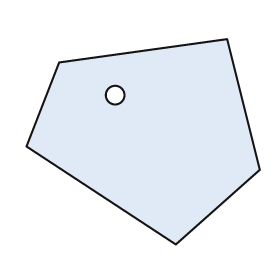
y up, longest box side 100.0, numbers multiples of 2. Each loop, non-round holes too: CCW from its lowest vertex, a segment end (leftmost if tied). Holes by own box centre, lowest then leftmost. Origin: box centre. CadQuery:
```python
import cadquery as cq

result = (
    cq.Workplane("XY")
    .moveTo(14.0, -44.0)
    .lineTo(50.0, -12.0)
    .lineTo(36.0, 44.0)
    .lineTo(-36.0, 34.0)
    .lineTo(-50.0, -2.0)
    .close()
    .moveTo(-12.0, 20.0)
    .circle(4.0)
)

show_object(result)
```